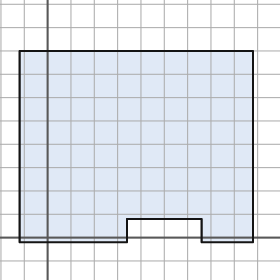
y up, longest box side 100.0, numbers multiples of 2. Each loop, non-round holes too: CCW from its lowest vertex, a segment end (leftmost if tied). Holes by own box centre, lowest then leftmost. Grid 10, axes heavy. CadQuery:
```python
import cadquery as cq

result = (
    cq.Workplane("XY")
    .moveTo(-12.0, -2.0)
    .lineTo(34.0, -2.0)
    .lineTo(34.0, 8.0)
    .lineTo(66.0, 8.0)
    .lineTo(66.0, -2.0)
    .lineTo(88.0, -2.0)
    .lineTo(88.0, 80.0)
    .lineTo(-12.0, 80.0)
    .close()
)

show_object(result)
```